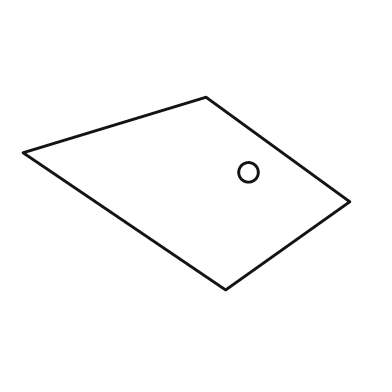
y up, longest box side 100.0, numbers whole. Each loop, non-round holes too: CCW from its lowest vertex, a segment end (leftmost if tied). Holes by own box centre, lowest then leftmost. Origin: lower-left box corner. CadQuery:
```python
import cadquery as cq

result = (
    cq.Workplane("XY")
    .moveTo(62.0, 0.0)
    .lineTo(100.0, 27.0)
    .lineTo(56.0, 59.0)
    .lineTo(0.0, 42.0)
    .close()
    .moveTo(69.0, 36.0)
    .circle(3.0)
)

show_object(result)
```